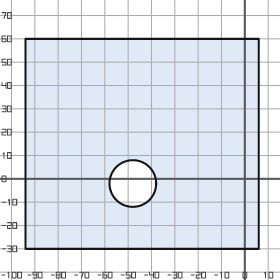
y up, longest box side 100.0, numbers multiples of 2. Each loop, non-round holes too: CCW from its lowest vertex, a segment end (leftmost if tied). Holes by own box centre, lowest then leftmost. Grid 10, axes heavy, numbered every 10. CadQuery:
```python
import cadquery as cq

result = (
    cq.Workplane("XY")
    .moveTo(-94.0, -30.0)
    .lineTo(6.0, -30.0)
    .lineTo(6.0, 60.0)
    .lineTo(-94.0, 60.0)
    .close()
    .moveTo(-48.0, -2.0)
    .circle(10.0)
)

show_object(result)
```